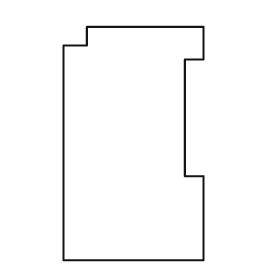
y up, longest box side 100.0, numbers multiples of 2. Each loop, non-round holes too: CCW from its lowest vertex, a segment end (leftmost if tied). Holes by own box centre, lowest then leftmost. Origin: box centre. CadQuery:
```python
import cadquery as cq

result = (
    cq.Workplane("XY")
    .moveTo(-30.0, -50.0)
    .lineTo(30.0, -50.0)
    .lineTo(30.0, -14.0)
    .lineTo(22.0, -14.0)
    .lineTo(22.0, 36.0)
    .lineTo(30.0, 36.0)
    .lineTo(30.0, 50.0)
    .lineTo(-20.0, 50.0)
    .lineTo(-20.0, 42.0)
    .lineTo(-30.0, 42.0)
    .close()
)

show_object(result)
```